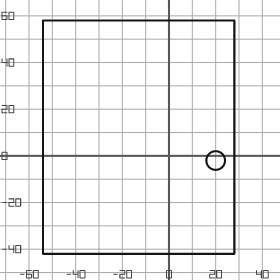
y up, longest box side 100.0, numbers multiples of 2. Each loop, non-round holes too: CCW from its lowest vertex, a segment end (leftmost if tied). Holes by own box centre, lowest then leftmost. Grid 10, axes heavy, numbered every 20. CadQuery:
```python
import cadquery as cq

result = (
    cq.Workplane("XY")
    .moveTo(-54.0, -42.0)
    .lineTo(28.0, -42.0)
    .lineTo(28.0, 58.0)
    .lineTo(-54.0, 58.0)
    .close()
    .moveTo(20.0, -2.0)
    .circle(4.0)
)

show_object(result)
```